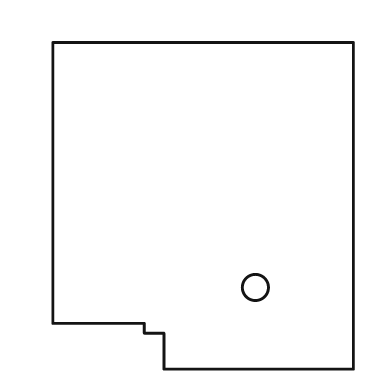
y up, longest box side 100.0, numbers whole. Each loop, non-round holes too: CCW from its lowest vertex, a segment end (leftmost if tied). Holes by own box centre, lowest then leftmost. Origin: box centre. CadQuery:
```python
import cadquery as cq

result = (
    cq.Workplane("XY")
    .moveTo(-12.0, -50.0)
    .lineTo(46.0, -50.0)
    .lineTo(46.0, 50.0)
    .lineTo(-46.0, 50.0)
    .lineTo(-46.0, -36.0)
    .lineTo(-18.0, -36.0)
    .lineTo(-18.0, -39.0)
    .lineTo(-12.0, -39.0)
    .close()
    .moveTo(16.0, -25.0)
    .circle(4.0)
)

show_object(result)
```